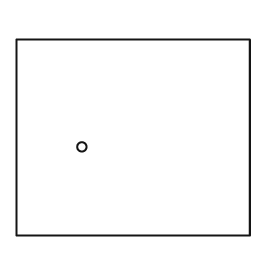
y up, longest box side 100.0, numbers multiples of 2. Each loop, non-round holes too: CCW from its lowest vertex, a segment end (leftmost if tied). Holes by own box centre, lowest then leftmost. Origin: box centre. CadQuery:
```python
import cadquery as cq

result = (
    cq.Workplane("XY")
    .moveTo(-50.0, -42.0)
    .lineTo(50.0, -42.0)
    .lineTo(50.0, 42.0)
    .lineTo(-50.0, 42.0)
    .close()
    .moveTo(-22.0, -4.0)
    .circle(2.0)
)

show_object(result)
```